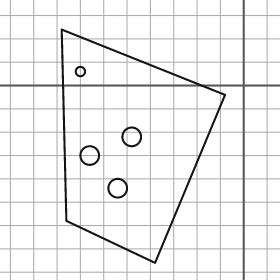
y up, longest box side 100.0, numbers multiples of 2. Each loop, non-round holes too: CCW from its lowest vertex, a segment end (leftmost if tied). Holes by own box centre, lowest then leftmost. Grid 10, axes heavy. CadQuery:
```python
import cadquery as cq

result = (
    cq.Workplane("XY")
    .moveTo(-38.0, -76.0)
    .lineTo(-8.0, -4.0)
    .lineTo(-78.0, 24.0)
    .lineTo(-76.0, -58.0)
    .close()
    .moveTo(-54.0, -44.0)
    .circle(4.0)
    .moveTo(-66.0, -30.0)
    .circle(4.0)
    .moveTo(-48.0, -22.0)
    .circle(4.0)
    .moveTo(-70.0, 6.0)
    .circle(2.0)
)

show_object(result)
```